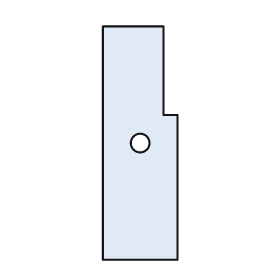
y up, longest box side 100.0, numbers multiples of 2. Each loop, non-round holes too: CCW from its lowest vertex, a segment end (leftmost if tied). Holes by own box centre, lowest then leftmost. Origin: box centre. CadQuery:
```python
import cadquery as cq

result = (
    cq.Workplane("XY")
    .moveTo(-16.0, -50.0)
    .lineTo(16.0, -50.0)
    .lineTo(16.0, 12.0)
    .lineTo(10.0, 12.0)
    .lineTo(10.0, 50.0)
    .lineTo(-16.0, 50.0)
    .close()
    .moveTo(0.0, 0.0)
    .circle(4.0)
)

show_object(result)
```